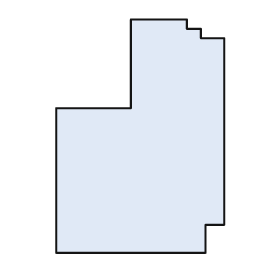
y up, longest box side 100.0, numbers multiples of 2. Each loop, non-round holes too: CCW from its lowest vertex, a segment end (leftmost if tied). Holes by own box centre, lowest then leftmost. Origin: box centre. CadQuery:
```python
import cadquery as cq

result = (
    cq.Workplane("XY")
    .moveTo(-36.0, -50.0)
    .lineTo(28.0, -50.0)
    .lineTo(28.0, -38.0)
    .lineTo(36.0, -38.0)
    .lineTo(36.0, 42.0)
    .lineTo(26.0, 42.0)
    .lineTo(26.0, 46.0)
    .lineTo(20.0, 46.0)
    .lineTo(20.0, 50.0)
    .lineTo(-4.0, 50.0)
    .lineTo(-4.0, 12.0)
    .lineTo(-36.0, 12.0)
    .close()
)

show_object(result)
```